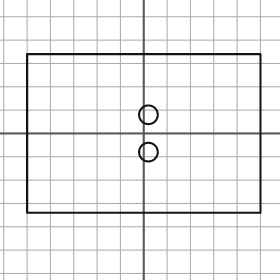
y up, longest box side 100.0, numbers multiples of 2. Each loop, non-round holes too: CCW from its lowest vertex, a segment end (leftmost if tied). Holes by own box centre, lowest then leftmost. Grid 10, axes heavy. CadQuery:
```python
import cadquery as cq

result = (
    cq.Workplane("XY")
    .moveTo(-50.0, -34.0)
    .lineTo(50.0, -34.0)
    .lineTo(50.0, 34.0)
    .lineTo(-50.0, 34.0)
    .close()
    .moveTo(2.0, -8.0)
    .circle(4.0)
    .moveTo(2.0, 8.0)
    .circle(4.0)
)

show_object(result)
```